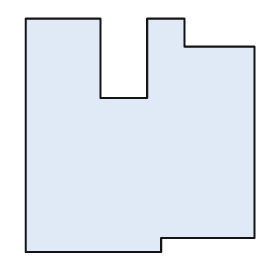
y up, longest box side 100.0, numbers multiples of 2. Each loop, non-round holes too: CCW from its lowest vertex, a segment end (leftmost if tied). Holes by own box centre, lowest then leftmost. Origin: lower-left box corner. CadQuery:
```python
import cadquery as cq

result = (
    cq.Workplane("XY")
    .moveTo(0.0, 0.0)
    .lineTo(58.0, 0.0)
    .lineTo(58.0, 6.0)
    .lineTo(98.0, 6.0)
    .lineTo(98.0, 88.0)
    .lineTo(68.0, 88.0)
    .lineTo(68.0, 100.0)
    .lineTo(52.0, 100.0)
    .lineTo(52.0, 66.0)
    .lineTo(32.0, 66.0)
    .lineTo(32.0, 100.0)
    .lineTo(0.0, 100.0)
    .close()
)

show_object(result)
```